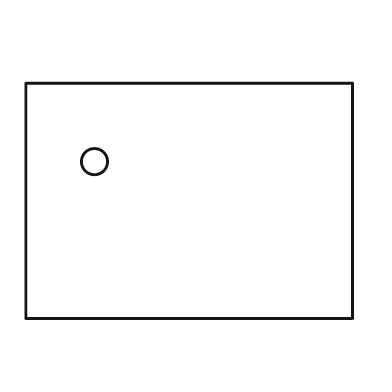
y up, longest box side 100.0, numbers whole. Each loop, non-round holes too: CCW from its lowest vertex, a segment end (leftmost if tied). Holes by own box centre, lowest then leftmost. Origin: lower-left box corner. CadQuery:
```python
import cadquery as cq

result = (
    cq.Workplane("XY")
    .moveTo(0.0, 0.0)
    .lineTo(100.0, 0.0)
    .lineTo(100.0, 72.0)
    .lineTo(0.0, 72.0)
    .close()
    .moveTo(21.0, 48.0)
    .circle(4.0)
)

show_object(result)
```